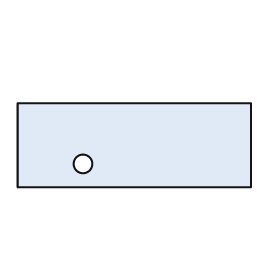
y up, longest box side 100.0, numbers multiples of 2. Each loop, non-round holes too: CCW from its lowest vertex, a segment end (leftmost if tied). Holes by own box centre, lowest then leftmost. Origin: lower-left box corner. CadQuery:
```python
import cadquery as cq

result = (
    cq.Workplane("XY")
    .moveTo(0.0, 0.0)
    .lineTo(100.0, 0.0)
    .lineTo(100.0, 36.0)
    .lineTo(0.0, 36.0)
    .close()
    .moveTo(28.0, 10.0)
    .circle(4.0)
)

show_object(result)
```